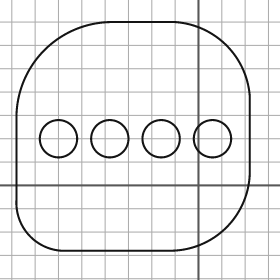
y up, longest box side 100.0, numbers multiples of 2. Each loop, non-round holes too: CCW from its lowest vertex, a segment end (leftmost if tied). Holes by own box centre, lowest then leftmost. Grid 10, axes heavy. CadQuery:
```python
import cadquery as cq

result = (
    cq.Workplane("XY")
    .moveTo(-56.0, -28.0)
    .lineTo(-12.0, -28.0)
    .threePointArc((12.0, -18.0), (22.0, 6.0))
    .lineTo(22.0, 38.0)
    .threePointArc((12.0, 60.0), (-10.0, 70.0))
    .lineTo(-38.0, 70.0)
    .threePointArc((-66.0, 58.0), (-78.0, 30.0))
    .lineTo(-78.0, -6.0)
    .threePointArc((-72.0, -22.0), (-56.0, -28.0))
    .close()
    .moveTo(-60.0, 20.0)
    .circle(8.0)
    .moveTo(-38.0, 20.0)
    .circle(8.0)
    .moveTo(-16.0, 20.0)
    .circle(8.0)
    .moveTo(6.0, 20.0)
    .circle(8.0)
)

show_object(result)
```